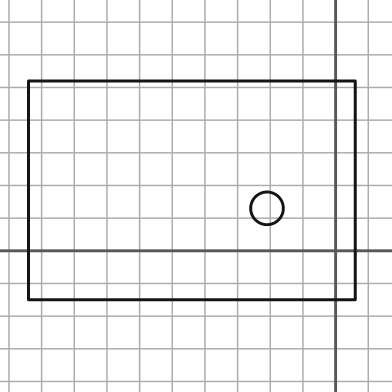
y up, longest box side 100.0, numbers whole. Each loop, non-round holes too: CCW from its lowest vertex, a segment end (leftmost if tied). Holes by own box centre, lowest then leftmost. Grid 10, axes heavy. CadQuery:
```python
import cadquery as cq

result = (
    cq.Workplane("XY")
    .moveTo(-94.0, -15.0)
    .lineTo(6.0, -15.0)
    .lineTo(6.0, 52.0)
    .lineTo(-94.0, 52.0)
    .close()
    .moveTo(-21.0, 13.0)
    .circle(5.0)
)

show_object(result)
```